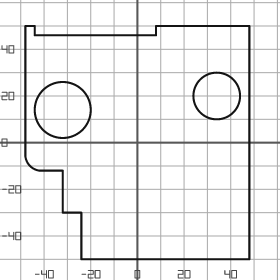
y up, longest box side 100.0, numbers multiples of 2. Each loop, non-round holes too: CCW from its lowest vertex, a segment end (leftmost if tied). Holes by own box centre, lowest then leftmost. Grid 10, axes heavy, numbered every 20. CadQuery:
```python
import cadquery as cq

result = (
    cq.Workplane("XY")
    .moveTo(-24.0, -50.0)
    .lineTo(48.0, -50.0)
    .lineTo(48.0, 50.0)
    .lineTo(8.0, 50.0)
    .lineTo(8.0, 46.0)
    .lineTo(-44.0, 46.0)
    .lineTo(-44.0, 50.0)
    .lineTo(-48.0, 50.0)
    .lineTo(-48.0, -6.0)
    .threePointArc((-46.0, -10.0), (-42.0, -12.0))
    .lineTo(-32.0, -12.0)
    .lineTo(-32.0, -30.0)
    .lineTo(-24.0, -30.0)
    .close()
    .moveTo(-32.0, 14.0)
    .circle(12.0)
    .moveTo(34.0, 20.0)
    .circle(10.0)
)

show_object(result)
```